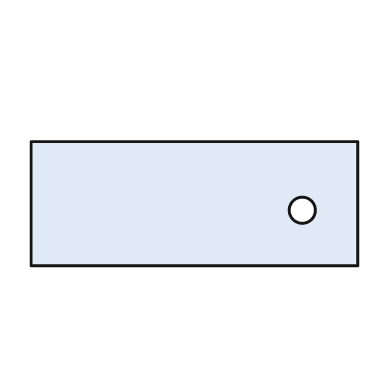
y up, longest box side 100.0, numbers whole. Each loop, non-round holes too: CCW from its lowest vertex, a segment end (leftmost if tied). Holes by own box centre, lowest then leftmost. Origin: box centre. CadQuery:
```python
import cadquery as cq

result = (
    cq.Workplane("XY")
    .moveTo(-50.0, -19.0)
    .lineTo(50.0, -19.0)
    .lineTo(50.0, 19.0)
    .lineTo(-50.0, 19.0)
    .close()
    .moveTo(33.0, -2.0)
    .circle(4.0)
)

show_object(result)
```